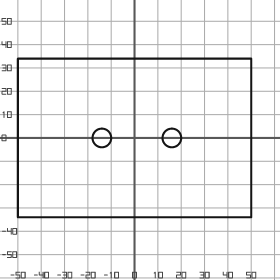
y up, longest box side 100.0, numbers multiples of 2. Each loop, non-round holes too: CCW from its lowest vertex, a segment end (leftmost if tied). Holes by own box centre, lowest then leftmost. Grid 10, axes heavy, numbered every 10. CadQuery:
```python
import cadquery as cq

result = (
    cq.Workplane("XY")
    .moveTo(-50.0, -34.0)
    .lineTo(50.0, -34.0)
    .lineTo(50.0, 34.0)
    .lineTo(-50.0, 34.0)
    .close()
    .moveTo(-14.0, 0.0)
    .circle(4.0)
    .moveTo(16.0, 0.0)
    .circle(4.0)
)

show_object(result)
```